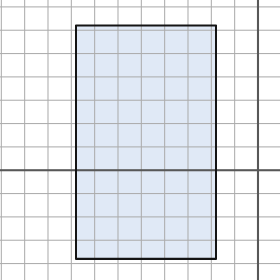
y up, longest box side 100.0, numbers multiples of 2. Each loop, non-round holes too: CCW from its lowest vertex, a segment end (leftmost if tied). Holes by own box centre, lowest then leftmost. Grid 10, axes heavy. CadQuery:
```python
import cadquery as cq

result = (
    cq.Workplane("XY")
    .moveTo(-78.0, -38.0)
    .lineTo(-18.0, -38.0)
    .lineTo(-18.0, 62.0)
    .lineTo(-78.0, 62.0)
    .close()
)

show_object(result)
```